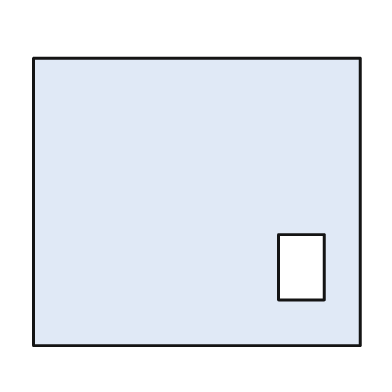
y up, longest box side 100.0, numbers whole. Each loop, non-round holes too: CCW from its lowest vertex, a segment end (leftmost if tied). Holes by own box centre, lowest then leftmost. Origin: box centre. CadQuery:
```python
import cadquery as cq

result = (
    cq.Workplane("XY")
    .moveTo(-50.0, -44.0)
    .lineTo(50.0, -44.0)
    .lineTo(50.0, 44.0)
    .lineTo(-50.0, 44.0)
    .close()
    .moveTo(25.0, -30.0)
    .lineTo(39.0, -30.0)
    .lineTo(39.0, -10.0)
    .lineTo(25.0, -10.0)
    .close()
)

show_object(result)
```